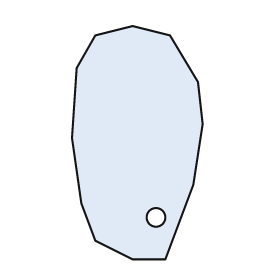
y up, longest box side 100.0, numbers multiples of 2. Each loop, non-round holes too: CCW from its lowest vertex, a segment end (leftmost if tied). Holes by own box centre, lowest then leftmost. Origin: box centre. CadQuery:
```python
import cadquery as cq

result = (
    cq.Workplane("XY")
    .moveTo(-2.0, -50.0)
    .lineTo(12.0, -50.0)
    .lineTo(24.0, -18.0)
    .lineTo(28.0, 8.0)
    .lineTo(26.0, 26.0)
    .lineTo(14.0, 46.0)
    .lineTo(-2.0, 50.0)
    .lineTo(-18.0, 46.0)
    .lineTo(-26.0, 32.0)
    .lineTo(-28.0, 2.0)
    .lineTo(-24.0, -26.0)
    .lineTo(-18.0, -42.0)
    .close()
    .moveTo(8.0, -32.0)
    .circle(4.0)
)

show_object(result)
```